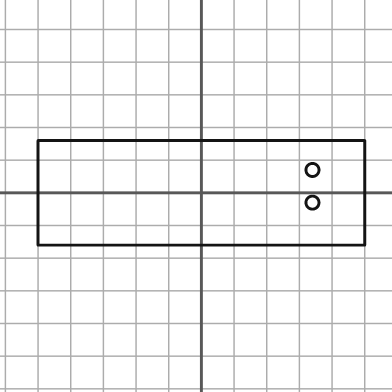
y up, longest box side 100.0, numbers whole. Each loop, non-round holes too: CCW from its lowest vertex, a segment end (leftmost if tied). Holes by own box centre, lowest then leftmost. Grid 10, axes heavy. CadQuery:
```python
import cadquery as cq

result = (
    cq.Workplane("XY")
    .moveTo(-50.0, -16.0)
    .lineTo(50.0, -16.0)
    .lineTo(50.0, 16.0)
    .lineTo(-50.0, 16.0)
    .close()
    .moveTo(34.0, -3.0)
    .circle(2.0)
    .moveTo(34.0, 7.0)
    .circle(2.0)
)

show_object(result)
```